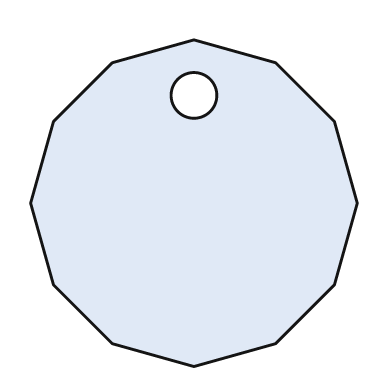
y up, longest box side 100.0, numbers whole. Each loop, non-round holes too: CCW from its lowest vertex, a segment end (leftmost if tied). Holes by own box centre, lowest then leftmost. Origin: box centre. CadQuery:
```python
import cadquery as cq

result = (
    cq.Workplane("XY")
    .moveTo(0.0, -50.0)
    .lineTo(25.0, -43.0)
    .lineTo(43.0, -25.0)
    .lineTo(50.0, 0.0)
    .lineTo(43.0, 25.0)
    .lineTo(25.0, 43.0)
    .lineTo(0.0, 50.0)
    .lineTo(-25.0, 43.0)
    .lineTo(-43.0, 25.0)
    .lineTo(-50.0, 0.0)
    .lineTo(-43.0, -25.0)
    .lineTo(-25.0, -43.0)
    .close()
    .moveTo(0.0, 33.0)
    .circle(7.0)
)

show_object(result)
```